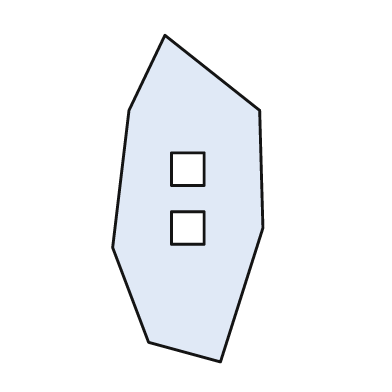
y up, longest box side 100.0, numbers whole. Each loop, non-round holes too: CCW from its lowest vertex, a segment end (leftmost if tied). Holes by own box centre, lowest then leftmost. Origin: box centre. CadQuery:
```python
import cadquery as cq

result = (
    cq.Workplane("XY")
    .moveTo(10.0, -50.0)
    .lineTo(23.0, -9.0)
    .lineTo(22.0, 27.0)
    .lineTo(-7.0, 50.0)
    .lineTo(-18.0, 27.0)
    .lineTo(-23.0, -15.0)
    .lineTo(-12.0, -44.0)
    .close()
    .moveTo(-5.0, -14.0)
    .lineTo(5.0, -14.0)
    .lineTo(5.0, -4.0)
    .lineTo(-5.0, -4.0)
    .close()
    .moveTo(-5.0, 4.0)
    .lineTo(5.0, 4.0)
    .lineTo(5.0, 14.0)
    .lineTo(-5.0, 14.0)
    .close()
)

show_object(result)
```